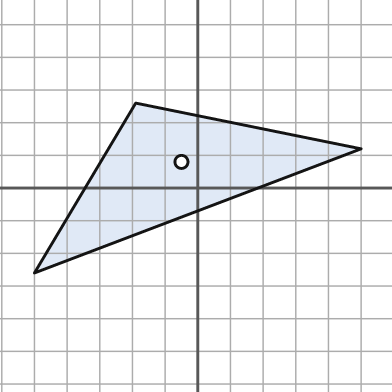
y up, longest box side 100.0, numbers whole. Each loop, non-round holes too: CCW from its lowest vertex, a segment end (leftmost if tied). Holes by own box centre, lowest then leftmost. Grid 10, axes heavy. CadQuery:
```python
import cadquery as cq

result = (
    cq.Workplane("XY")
    .moveTo(-50.0, -26.0)
    .lineTo(50.0, 12.0)
    .lineTo(-19.0, 26.0)
    .close()
    .moveTo(-5.0, 8.0)
    .circle(2.0)
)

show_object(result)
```